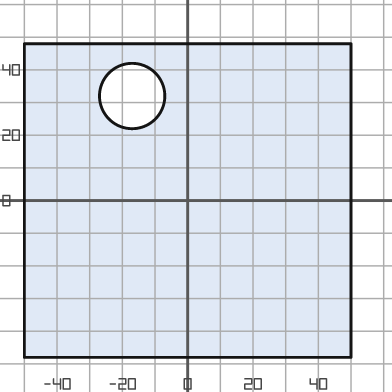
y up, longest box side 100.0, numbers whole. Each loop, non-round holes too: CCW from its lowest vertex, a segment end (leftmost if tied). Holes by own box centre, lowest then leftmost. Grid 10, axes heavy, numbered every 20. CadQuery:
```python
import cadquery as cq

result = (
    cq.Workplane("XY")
    .moveTo(-50.0, -48.0)
    .lineTo(50.0, -48.0)
    .lineTo(50.0, 48.0)
    .lineTo(-50.0, 48.0)
    .close()
    .moveTo(-17.0, 32.0)
    .circle(10.0)
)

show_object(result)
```